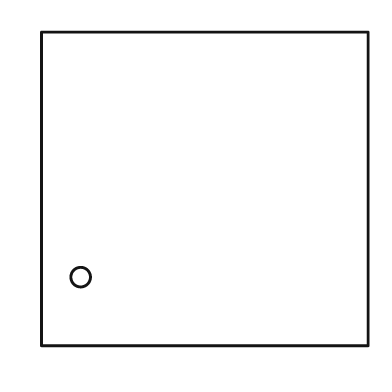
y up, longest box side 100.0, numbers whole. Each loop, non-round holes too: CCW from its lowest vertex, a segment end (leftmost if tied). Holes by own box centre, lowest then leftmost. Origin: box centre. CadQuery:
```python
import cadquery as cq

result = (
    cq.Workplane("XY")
    .moveTo(-50.0, -48.0)
    .lineTo(50.0, -48.0)
    .lineTo(50.0, 48.0)
    .lineTo(-50.0, 48.0)
    .close()
    .moveTo(-38.0, -27.0)
    .circle(3.0)
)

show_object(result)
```